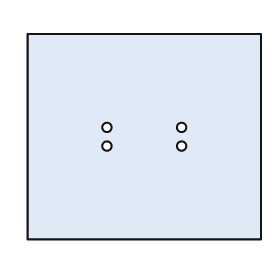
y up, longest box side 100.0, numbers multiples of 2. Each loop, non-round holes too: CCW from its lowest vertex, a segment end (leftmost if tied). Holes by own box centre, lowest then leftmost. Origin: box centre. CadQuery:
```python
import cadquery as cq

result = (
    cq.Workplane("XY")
    .moveTo(-50.0, -44.0)
    .lineTo(50.0, -44.0)
    .lineTo(50.0, 44.0)
    .lineTo(-50.0, 44.0)
    .close()
    .moveTo(-16.0, -4.0)
    .circle(2.0)
    .moveTo(16.0, -4.0)
    .circle(2.0)
    .moveTo(-16.0, 4.0)
    .circle(2.0)
    .moveTo(16.0, 4.0)
    .circle(2.0)
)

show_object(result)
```